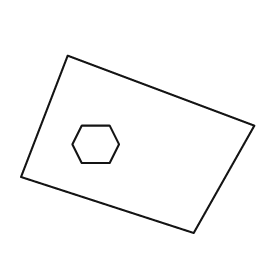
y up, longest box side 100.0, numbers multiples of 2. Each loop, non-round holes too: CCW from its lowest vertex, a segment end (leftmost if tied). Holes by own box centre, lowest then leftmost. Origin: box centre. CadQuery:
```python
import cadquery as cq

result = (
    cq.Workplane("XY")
    .moveTo(24.0, -38.0)
    .lineTo(50.0, 8.0)
    .lineTo(-30.0, 38.0)
    .lineTo(-50.0, -14.0)
    .close()
    .moveTo(-24.0, -8.0)
    .lineTo(-12.0, -8.0)
    .lineTo(-8.0, 0.0)
    .lineTo(-12.0, 8.0)
    .lineTo(-24.0, 8.0)
    .lineTo(-28.0, 0.0)
    .close()
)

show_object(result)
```